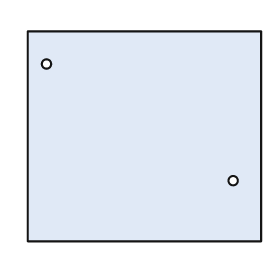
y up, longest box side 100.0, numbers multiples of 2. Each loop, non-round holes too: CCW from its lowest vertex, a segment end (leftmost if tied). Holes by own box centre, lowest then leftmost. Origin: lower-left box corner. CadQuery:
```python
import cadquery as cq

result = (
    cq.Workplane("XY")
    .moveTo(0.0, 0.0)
    .lineTo(100.0, 0.0)
    .lineTo(100.0, 90.0)
    .lineTo(0.0, 90.0)
    .close()
    .moveTo(88.0, 26.0)
    .circle(2.0)
    .moveTo(8.0, 76.0)
    .circle(2.0)
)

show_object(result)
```